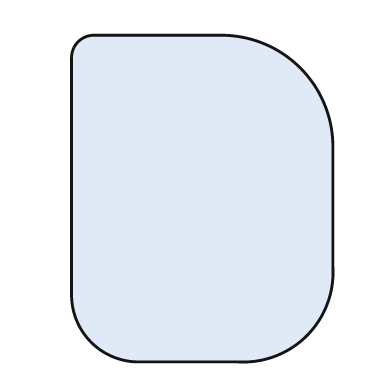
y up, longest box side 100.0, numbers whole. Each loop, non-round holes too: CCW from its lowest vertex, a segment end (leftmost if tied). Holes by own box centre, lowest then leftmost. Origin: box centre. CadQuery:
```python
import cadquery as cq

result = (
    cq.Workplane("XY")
    .moveTo(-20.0, -50.0)
    .lineTo(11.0, -50.0)
    .threePointArc((32.0, -42.0), (40.0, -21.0))
    .lineTo(40.0, 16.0)
    .threePointArc((30.0, 40.0), (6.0, 50.0))
    .lineTo(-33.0, 50.0)
    .threePointArc((-38.0, 48.0), (-40.0, 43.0))
    .lineTo(-40.0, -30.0)
    .threePointArc((-34.0, -44.0), (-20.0, -50.0))
    .close()
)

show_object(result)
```